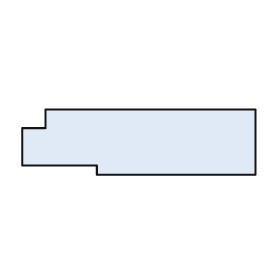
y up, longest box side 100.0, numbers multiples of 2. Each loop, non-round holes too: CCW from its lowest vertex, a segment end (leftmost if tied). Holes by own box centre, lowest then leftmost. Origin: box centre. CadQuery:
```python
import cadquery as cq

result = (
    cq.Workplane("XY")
    .moveTo(-18.0, -14.0)
    .lineTo(50.0, -14.0)
    .lineTo(50.0, 14.0)
    .lineTo(-40.0, 14.0)
    .lineTo(-40.0, 6.0)
    .lineTo(-50.0, 6.0)
    .lineTo(-50.0, -10.0)
    .lineTo(-18.0, -10.0)
    .close()
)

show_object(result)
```